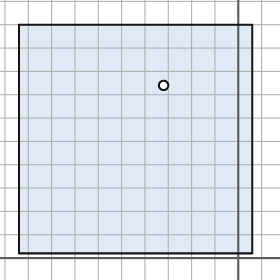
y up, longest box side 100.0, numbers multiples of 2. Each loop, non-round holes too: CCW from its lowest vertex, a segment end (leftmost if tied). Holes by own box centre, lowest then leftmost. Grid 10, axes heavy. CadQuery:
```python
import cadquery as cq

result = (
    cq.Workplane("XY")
    .moveTo(-94.0, 2.0)
    .lineTo(6.0, 2.0)
    .lineTo(6.0, 100.0)
    .lineTo(-94.0, 100.0)
    .close()
    .moveTo(-32.0, 74.0)
    .circle(2.0)
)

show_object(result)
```